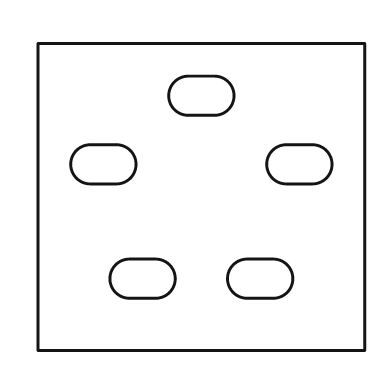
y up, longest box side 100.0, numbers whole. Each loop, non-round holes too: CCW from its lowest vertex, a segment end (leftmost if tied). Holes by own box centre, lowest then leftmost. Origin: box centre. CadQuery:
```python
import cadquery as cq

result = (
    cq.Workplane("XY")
    .moveTo(-50.0, -47.0)
    .lineTo(50.0, -47.0)
    .lineTo(50.0, 47.0)
    .lineTo(-50.0, 47.0)
    .close()
    .moveTo(-22.0, -31.0)
    .lineTo(-14.0, -31.0)
    .threePointArc((-8.0, -25.0), (-14.0, -19.0))
    .lineTo(-22.0, -19.0)
    .threePointArc((-28.0, -25.0), (-22.0, -31.0))
    .close()
    .moveTo(14.0, -31.0)
    .lineTo(22.0, -31.0)
    .threePointArc((28.0, -25.0), (22.0, -19.0))
    .lineTo(14.0, -19.0)
    .threePointArc((8.0, -25.0), (14.0, -31.0))
    .close()
    .moveTo(-34.0, 4.0)
    .lineTo(-26.0, 4.0)
    .threePointArc((-20.0, 10.0), (-26.0, 16.0))
    .lineTo(-34.0, 16.0)
    .threePointArc((-40.0, 10.0), (-34.0, 4.0))
    .close()
    .moveTo(26.0, 4.0)
    .lineTo(34.0, 4.0)
    .threePointArc((40.0, 10.0), (34.0, 16.0))
    .lineTo(26.0, 16.0)
    .threePointArc((20.0, 10.0), (26.0, 4.0))
    .close()
    .moveTo(-4.0, 25.0)
    .lineTo(4.0, 25.0)
    .threePointArc((10.0, 31.0), (4.0, 37.0))
    .lineTo(-4.0, 37.0)
    .threePointArc((-10.0, 31.0), (-4.0, 25.0))
    .close()
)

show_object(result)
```